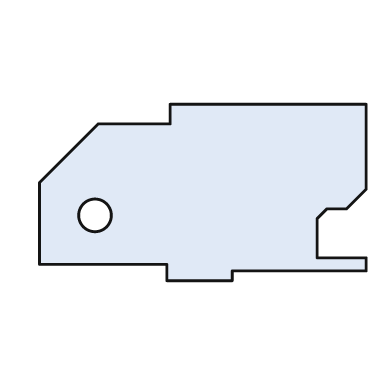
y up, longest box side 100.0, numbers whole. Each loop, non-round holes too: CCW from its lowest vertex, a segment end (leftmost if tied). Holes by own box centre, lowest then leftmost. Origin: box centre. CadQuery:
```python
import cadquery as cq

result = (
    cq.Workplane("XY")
    .moveTo(-11.0, -27.0)
    .lineTo(9.0, -27.0)
    .lineTo(9.0, -24.0)
    .lineTo(50.0, -24.0)
    .lineTo(50.0, -20.0)
    .lineTo(35.0, -20.0)
    .lineTo(35.0, -8.0)
    .lineTo(38.0, -5.0)
    .lineTo(44.0, -5.0)
    .lineTo(50.0, 1.0)
    .lineTo(50.0, 27.0)
    .lineTo(-10.0, 27.0)
    .lineTo(-10.0, 21.0)
    .lineTo(-32.0, 21.0)
    .lineTo(-50.0, 3.0)
    .lineTo(-50.0, -22.0)
    .lineTo(-11.0, -22.0)
    .close()
    .moveTo(-33.0, -7.0)
    .circle(5.0)
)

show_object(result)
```